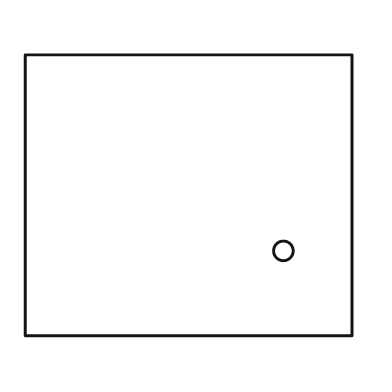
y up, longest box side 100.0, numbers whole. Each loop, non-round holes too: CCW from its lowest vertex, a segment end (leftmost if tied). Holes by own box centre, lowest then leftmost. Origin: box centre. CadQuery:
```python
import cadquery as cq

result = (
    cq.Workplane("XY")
    .moveTo(-50.0, -43.0)
    .lineTo(50.0, -43.0)
    .lineTo(50.0, 43.0)
    .lineTo(-50.0, 43.0)
    .close()
    .moveTo(29.0, -17.0)
    .circle(3.0)
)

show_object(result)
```